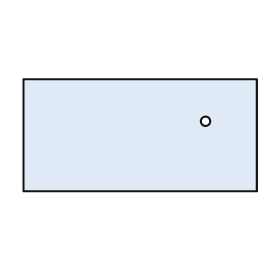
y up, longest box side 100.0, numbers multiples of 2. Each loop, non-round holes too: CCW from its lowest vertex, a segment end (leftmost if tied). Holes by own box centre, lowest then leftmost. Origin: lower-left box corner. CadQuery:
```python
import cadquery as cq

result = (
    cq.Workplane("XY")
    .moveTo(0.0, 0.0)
    .lineTo(100.0, 0.0)
    .lineTo(100.0, 48.0)
    .lineTo(0.0, 48.0)
    .close()
    .moveTo(78.0, 30.0)
    .circle(2.0)
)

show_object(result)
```